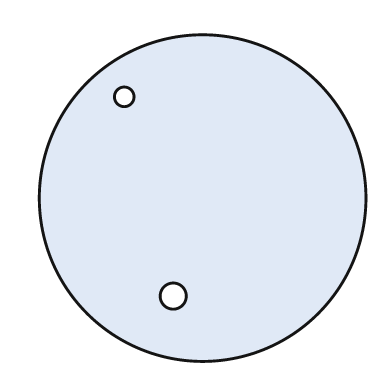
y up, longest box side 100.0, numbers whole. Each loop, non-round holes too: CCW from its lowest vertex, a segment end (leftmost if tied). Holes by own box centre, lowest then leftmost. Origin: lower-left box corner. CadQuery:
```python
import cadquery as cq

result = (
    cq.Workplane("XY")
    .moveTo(50.0, 50.0)
    .circle(50.0)
    .moveTo(41.0, 20.0)
    .circle(4.0)
    .moveTo(26.0, 81.0)
    .circle(3.0)
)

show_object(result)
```